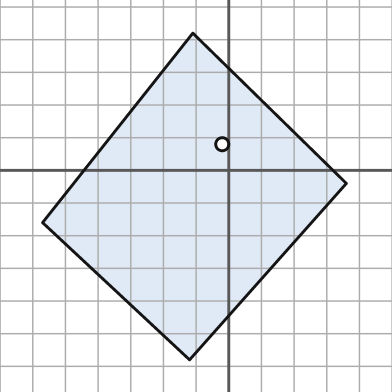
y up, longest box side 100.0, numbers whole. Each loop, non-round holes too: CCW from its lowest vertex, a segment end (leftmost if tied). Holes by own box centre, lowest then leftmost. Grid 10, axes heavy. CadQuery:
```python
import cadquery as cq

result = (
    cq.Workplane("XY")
    .moveTo(-12.0, -58.0)
    .lineTo(36.0, -4.0)
    .lineTo(-11.0, 42.0)
    .lineTo(-57.0, -16.0)
    .close()
    .moveTo(-2.0, 8.0)
    .circle(2.0)
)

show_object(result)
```